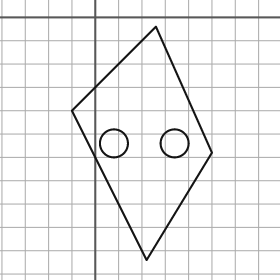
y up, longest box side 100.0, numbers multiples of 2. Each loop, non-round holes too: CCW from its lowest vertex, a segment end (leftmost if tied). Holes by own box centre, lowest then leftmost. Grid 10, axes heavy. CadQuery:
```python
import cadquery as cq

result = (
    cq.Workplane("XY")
    .moveTo(22.0, -104.0)
    .lineTo(50.0, -58.0)
    .lineTo(26.0, -4.0)
    .lineTo(-10.0, -40.0)
    .close()
    .moveTo(8.0, -54.0)
    .circle(6.0)
    .moveTo(34.0, -54.0)
    .circle(6.0)
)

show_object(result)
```